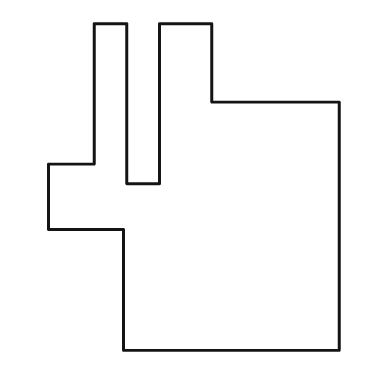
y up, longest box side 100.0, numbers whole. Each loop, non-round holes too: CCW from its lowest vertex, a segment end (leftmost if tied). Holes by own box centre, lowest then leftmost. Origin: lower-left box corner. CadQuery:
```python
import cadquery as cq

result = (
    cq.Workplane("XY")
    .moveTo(23.0, 0.0)
    .lineTo(89.0, 0.0)
    .lineTo(89.0, 76.0)
    .lineTo(50.0, 76.0)
    .lineTo(50.0, 100.0)
    .lineTo(34.0, 100.0)
    .lineTo(34.0, 51.0)
    .lineTo(24.0, 51.0)
    .lineTo(24.0, 100.0)
    .lineTo(14.0, 100.0)
    .lineTo(14.0, 57.0)
    .lineTo(0.0, 57.0)
    .lineTo(0.0, 37.0)
    .lineTo(23.0, 37.0)
    .close()
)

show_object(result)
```